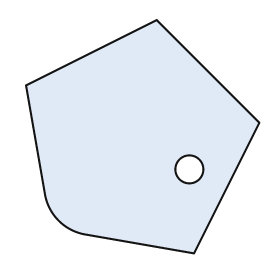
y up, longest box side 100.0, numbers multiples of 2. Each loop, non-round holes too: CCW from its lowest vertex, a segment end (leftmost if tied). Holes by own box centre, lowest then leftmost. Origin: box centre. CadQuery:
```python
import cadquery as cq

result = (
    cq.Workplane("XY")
    .moveTo(22.0, -50.0)
    .lineTo(50.0, 6.0)
    .lineTo(6.0, 50.0)
    .lineTo(-50.0, 22.0)
    .lineTo(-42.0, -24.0)
    .threePointArc((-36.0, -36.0), (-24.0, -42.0))
    .close()
    .moveTo(20.0, -14.0)
    .circle(6.0)
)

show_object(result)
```